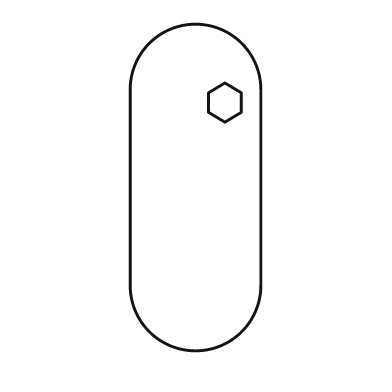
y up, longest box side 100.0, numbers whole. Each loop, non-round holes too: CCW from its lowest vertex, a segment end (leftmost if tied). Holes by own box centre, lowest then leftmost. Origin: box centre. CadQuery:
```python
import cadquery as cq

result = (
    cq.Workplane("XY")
    .moveTo(-20.0, -30.0)
    .threePointArc((0.0, -50.0), (20.0, -30.0))
    .lineTo(20.0, 30.0)
    .threePointArc((0.0, 50.0), (-20.0, 30.0))
    .close()
    .moveTo(9.0, 20.0)
    .lineTo(14.0, 23.0)
    .lineTo(14.0, 29.0)
    .lineTo(9.0, 32.0)
    .lineTo(4.0, 29.0)
    .lineTo(4.0, 23.0)
    .close()
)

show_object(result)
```